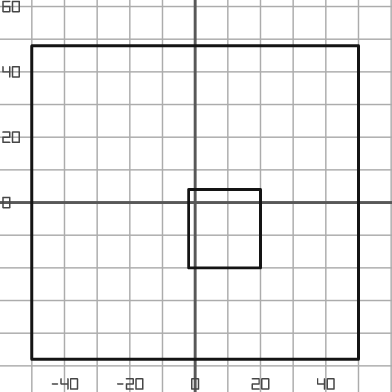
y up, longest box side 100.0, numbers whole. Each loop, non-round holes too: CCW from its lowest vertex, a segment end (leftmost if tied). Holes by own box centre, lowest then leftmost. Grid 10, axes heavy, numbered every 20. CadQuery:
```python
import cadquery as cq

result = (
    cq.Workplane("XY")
    .moveTo(-50.0, -48.0)
    .lineTo(50.0, -48.0)
    .lineTo(50.0, 48.0)
    .lineTo(-50.0, 48.0)
    .close()
    .moveTo(-2.0, -20.0)
    .lineTo(20.0, -20.0)
    .lineTo(20.0, 4.0)
    .lineTo(-2.0, 4.0)
    .close()
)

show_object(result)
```